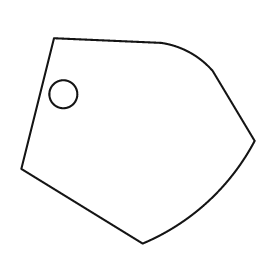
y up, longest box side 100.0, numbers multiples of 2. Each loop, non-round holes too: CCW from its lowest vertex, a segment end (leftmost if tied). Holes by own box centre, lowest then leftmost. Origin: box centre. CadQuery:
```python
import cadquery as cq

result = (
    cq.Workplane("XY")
    .moveTo(2.0, -44.0)
    .threePointArc((30.0, -26.0), (50.0, 0.0))
    .lineTo(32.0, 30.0)
    .threePointArc((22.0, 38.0), (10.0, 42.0))
    .lineTo(-36.0, 44.0)
    .lineTo(-50.0, -12.0)
    .close()
    .moveTo(-32.0, 20.0)
    .circle(6.0)
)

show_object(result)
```